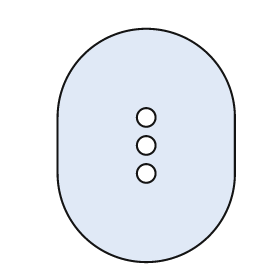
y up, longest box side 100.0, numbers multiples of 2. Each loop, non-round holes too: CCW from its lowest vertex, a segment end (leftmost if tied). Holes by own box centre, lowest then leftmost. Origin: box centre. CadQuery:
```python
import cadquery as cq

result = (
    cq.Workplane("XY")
    .moveTo(-38.0, -12.0)
    .threePointArc((0.0, -50.0), (38.0, -12.0))
    .lineTo(38.0, 12.0)
    .threePointArc((0.0, 50.0), (-38.0, 12.0))
    .close()
    .moveTo(0.0, -12.0)
    .circle(4.0)
    .moveTo(0.0, 0.0)
    .circle(4.0)
    .moveTo(0.0, 12.0)
    .circle(4.0)
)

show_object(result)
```